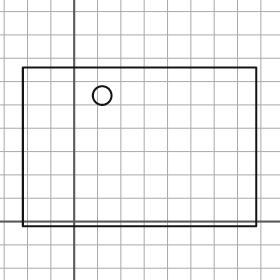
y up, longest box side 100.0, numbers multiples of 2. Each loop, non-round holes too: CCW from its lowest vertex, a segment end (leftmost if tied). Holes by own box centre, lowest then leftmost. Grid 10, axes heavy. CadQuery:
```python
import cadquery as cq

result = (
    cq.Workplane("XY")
    .moveTo(-22.0, -2.0)
    .lineTo(78.0, -2.0)
    .lineTo(78.0, 66.0)
    .lineTo(-22.0, 66.0)
    .close()
    .moveTo(12.0, 54.0)
    .circle(4.0)
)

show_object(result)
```